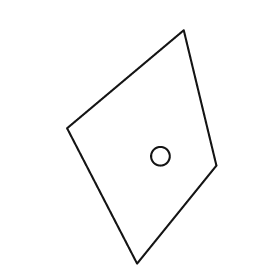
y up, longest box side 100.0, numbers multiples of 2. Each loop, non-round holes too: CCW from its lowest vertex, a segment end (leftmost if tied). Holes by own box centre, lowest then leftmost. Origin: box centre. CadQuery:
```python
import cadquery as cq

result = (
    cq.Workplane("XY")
    .moveTo(-2.0, -50.0)
    .lineTo(32.0, -8.0)
    .lineTo(18.0, 50.0)
    .lineTo(-32.0, 8.0)
    .close()
    .moveTo(8.0, -4.0)
    .circle(4.0)
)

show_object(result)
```